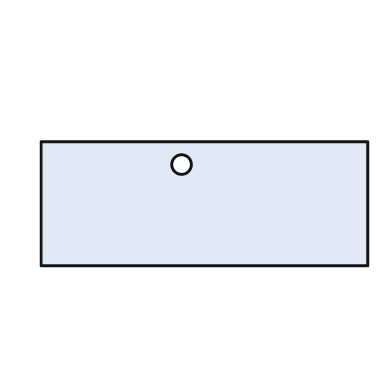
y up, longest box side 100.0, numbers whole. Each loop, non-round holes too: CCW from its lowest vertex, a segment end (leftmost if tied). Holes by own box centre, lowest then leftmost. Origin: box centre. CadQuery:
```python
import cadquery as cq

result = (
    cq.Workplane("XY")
    .moveTo(-50.0, -19.0)
    .lineTo(50.0, -19.0)
    .lineTo(50.0, 19.0)
    .lineTo(-50.0, 19.0)
    .close()
    .moveTo(-7.0, 12.0)
    .circle(3.0)
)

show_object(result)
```